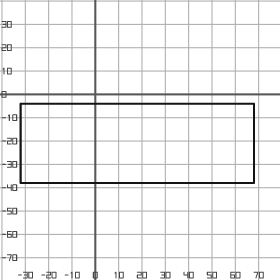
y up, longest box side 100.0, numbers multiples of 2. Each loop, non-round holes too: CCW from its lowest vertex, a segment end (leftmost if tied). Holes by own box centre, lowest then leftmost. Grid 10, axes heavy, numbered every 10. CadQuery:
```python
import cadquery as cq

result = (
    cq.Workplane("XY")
    .moveTo(-32.0, -38.0)
    .lineTo(68.0, -38.0)
    .lineTo(68.0, -4.0)
    .lineTo(-32.0, -4.0)
    .close()
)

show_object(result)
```